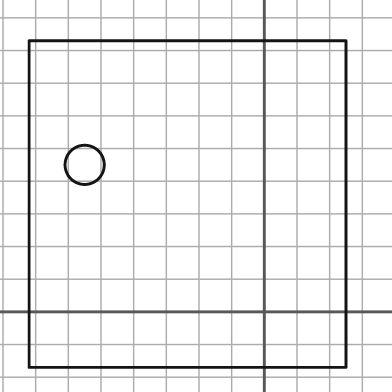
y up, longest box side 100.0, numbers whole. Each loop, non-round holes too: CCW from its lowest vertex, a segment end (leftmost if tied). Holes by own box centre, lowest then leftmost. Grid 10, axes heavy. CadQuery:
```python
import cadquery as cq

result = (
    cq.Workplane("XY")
    .moveTo(-72.0, -17.0)
    .lineTo(25.0, -17.0)
    .lineTo(25.0, 83.0)
    .lineTo(-72.0, 83.0)
    .close()
    .moveTo(-55.0, 45.0)
    .circle(6.0)
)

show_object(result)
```